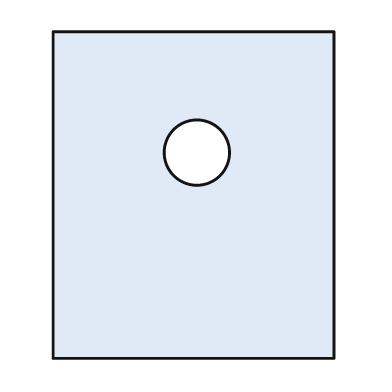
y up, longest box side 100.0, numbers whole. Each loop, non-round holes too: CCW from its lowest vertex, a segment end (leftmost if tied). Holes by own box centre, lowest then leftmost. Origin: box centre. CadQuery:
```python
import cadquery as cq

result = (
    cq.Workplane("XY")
    .moveTo(-43.0, -50.0)
    .lineTo(43.0, -50.0)
    .lineTo(43.0, 50.0)
    .lineTo(-43.0, 50.0)
    .close()
    .moveTo(1.0, 13.0)
    .circle(10.0)
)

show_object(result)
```